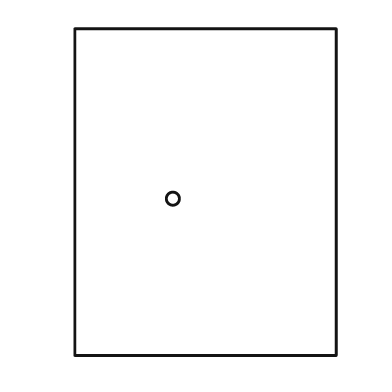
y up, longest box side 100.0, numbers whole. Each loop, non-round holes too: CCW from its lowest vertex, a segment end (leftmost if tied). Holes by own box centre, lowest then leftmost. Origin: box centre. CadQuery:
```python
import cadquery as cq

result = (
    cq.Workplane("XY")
    .moveTo(-40.0, -50.0)
    .lineTo(40.0, -50.0)
    .lineTo(40.0, 50.0)
    .lineTo(-40.0, 50.0)
    .close()
    .moveTo(-10.0, -2.0)
    .circle(2.0)
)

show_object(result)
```